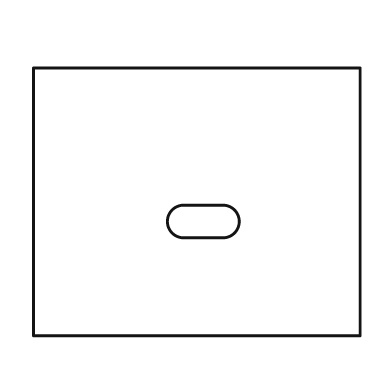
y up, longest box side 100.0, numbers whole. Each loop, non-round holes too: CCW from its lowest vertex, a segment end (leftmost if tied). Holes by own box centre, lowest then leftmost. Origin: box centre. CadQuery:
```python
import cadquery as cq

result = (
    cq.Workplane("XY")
    .moveTo(-50.0, -41.0)
    .lineTo(50.0, -41.0)
    .lineTo(50.0, 41.0)
    .lineTo(-50.0, 41.0)
    .close()
    .moveTo(-4.0, -11.0)
    .lineTo(8.0, -11.0)
    .threePointArc((13.0, -6.0), (8.0, -1.0))
    .lineTo(-4.0, -1.0)
    .threePointArc((-9.0, -6.0), (-4.0, -11.0))
    .close()
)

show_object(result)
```